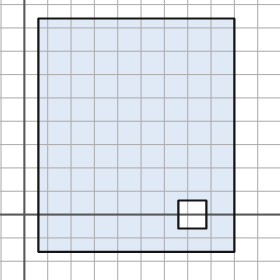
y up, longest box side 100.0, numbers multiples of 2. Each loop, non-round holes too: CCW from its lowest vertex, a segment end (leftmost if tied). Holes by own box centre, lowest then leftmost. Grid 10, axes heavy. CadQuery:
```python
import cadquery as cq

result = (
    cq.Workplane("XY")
    .moveTo(6.0, -16.0)
    .lineTo(90.0, -16.0)
    .lineTo(90.0, 84.0)
    .lineTo(6.0, 84.0)
    .close()
    .moveTo(66.0, -6.0)
    .lineTo(78.0, -6.0)
    .lineTo(78.0, 6.0)
    .lineTo(66.0, 6.0)
    .close()
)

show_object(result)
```